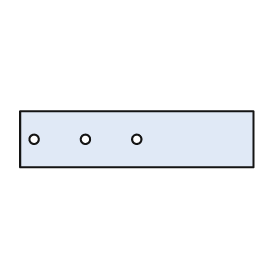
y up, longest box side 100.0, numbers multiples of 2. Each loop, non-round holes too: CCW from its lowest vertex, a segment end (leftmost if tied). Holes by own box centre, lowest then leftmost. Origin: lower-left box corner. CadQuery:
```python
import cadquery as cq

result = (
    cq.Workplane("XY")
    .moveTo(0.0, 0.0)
    .lineTo(100.0, 0.0)
    .lineTo(100.0, 24.0)
    .lineTo(0.0, 24.0)
    .close()
    .moveTo(6.0, 12.0)
    .circle(2.0)
    .moveTo(28.0, 12.0)
    .circle(2.0)
    .moveTo(50.0, 12.0)
    .circle(2.0)
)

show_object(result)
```